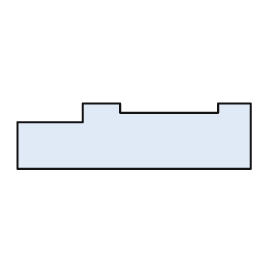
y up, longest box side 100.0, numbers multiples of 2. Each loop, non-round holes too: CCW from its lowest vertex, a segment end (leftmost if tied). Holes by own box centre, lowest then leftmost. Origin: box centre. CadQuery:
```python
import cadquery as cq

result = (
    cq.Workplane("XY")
    .moveTo(-50.0, -14.0)
    .lineTo(50.0, -14.0)
    .lineTo(50.0, 14.0)
    .lineTo(36.0, 14.0)
    .lineTo(36.0, 10.0)
    .lineTo(-6.0, 10.0)
    .lineTo(-6.0, 14.0)
    .lineTo(-22.0, 14.0)
    .lineTo(-22.0, 6.0)
    .lineTo(-50.0, 6.0)
    .close()
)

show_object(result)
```